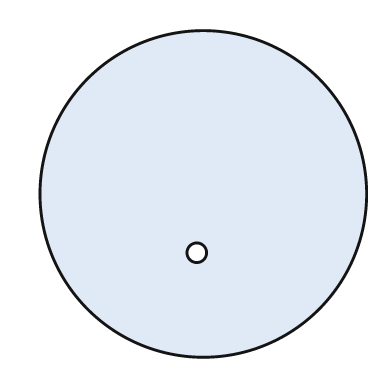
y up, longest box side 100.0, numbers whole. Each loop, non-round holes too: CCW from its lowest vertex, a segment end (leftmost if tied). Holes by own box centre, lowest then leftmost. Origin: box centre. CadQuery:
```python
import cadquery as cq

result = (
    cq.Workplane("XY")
    .moveTo(0.0, 0.0)
    .circle(50.0)
    .moveTo(-2.0, -18.0)
    .circle(3.0)
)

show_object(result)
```